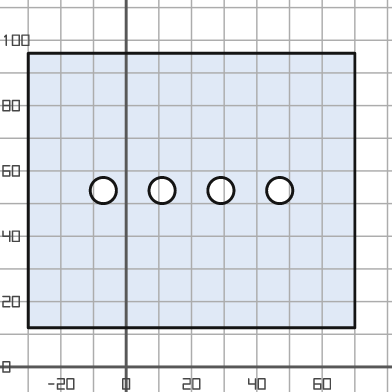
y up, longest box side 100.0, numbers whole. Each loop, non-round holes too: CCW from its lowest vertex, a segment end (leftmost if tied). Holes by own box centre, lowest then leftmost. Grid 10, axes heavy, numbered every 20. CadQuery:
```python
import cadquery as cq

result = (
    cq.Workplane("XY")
    .moveTo(-30.0, 12.0)
    .lineTo(70.0, 12.0)
    .lineTo(70.0, 96.0)
    .lineTo(-30.0, 96.0)
    .close()
    .moveTo(-7.0, 54.0)
    .circle(4.0)
    .moveTo(11.0, 54.0)
    .circle(4.0)
    .moveTo(29.0, 54.0)
    .circle(4.0)
    .moveTo(47.0, 54.0)
    .circle(4.0)
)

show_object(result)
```